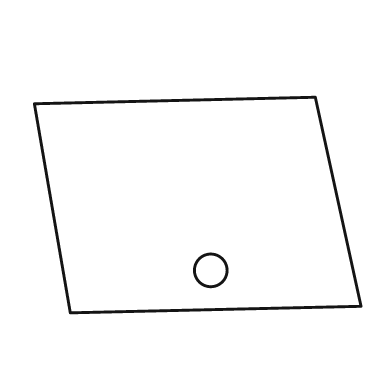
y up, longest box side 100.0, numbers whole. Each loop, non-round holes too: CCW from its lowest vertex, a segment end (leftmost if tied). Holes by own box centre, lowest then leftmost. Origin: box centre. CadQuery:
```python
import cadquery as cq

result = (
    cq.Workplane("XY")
    .moveTo(-39.0, -33.0)
    .lineTo(50.0, -31.0)
    .lineTo(36.0, 33.0)
    .lineTo(-50.0, 31.0)
    .close()
    .moveTo(4.0, -20.0)
    .circle(5.0)
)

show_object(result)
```